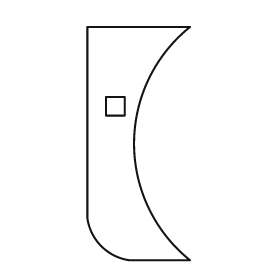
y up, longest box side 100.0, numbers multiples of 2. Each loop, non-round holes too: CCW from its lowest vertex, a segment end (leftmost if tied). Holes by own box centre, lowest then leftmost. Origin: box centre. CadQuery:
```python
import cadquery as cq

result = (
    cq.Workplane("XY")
    .moveTo(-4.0, -50.0)
    .lineTo(22.0, -50.0)
    .threePointArc((-2.0, 0.0), (22.0, 50.0))
    .lineTo(-22.0, 50.0)
    .lineTo(-22.0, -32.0)
    .threePointArc((-16.0, -44.0), (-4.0, -50.0))
    .close()
    .moveTo(-14.0, 12.0)
    .lineTo(-6.0, 12.0)
    .lineTo(-6.0, 20.0)
    .lineTo(-14.0, 20.0)
    .close()
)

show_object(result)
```